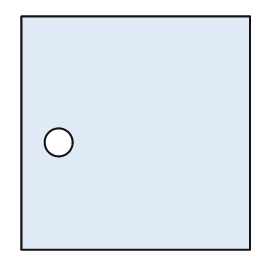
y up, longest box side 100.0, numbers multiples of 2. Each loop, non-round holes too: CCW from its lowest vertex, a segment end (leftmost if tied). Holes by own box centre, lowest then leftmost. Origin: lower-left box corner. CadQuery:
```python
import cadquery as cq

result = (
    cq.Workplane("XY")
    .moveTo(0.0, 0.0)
    .lineTo(98.0, 0.0)
    .lineTo(98.0, 100.0)
    .lineTo(0.0, 100.0)
    .close()
    .moveTo(16.0, 46.0)
    .circle(6.0)
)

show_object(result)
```